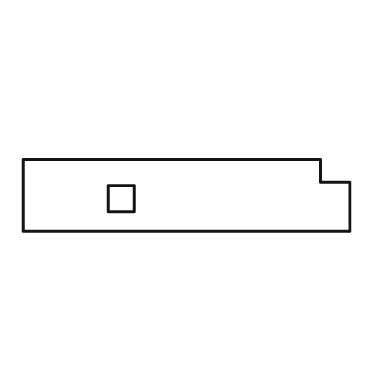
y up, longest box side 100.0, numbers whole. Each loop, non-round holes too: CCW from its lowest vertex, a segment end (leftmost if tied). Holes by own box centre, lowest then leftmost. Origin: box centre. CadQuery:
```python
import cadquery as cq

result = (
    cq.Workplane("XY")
    .moveTo(-50.0, -11.0)
    .lineTo(50.0, -11.0)
    .lineTo(50.0, 4.0)
    .lineTo(41.0, 4.0)
    .lineTo(41.0, 11.0)
    .lineTo(-50.0, 11.0)
    .close()
    .moveTo(-24.0, -5.0)
    .lineTo(-16.0, -5.0)
    .lineTo(-16.0, 3.0)
    .lineTo(-24.0, 3.0)
    .close()
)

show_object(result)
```